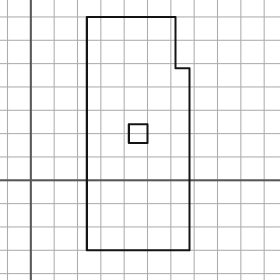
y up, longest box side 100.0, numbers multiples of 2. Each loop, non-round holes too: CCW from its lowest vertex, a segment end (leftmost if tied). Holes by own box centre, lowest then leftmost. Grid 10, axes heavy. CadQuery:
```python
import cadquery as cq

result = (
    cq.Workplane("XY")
    .moveTo(24.0, -30.0)
    .lineTo(68.0, -30.0)
    .lineTo(68.0, 48.0)
    .lineTo(62.0, 48.0)
    .lineTo(62.0, 70.0)
    .lineTo(24.0, 70.0)
    .close()
    .moveTo(42.0, 16.0)
    .lineTo(50.0, 16.0)
    .lineTo(50.0, 24.0)
    .lineTo(42.0, 24.0)
    .close()
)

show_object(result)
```